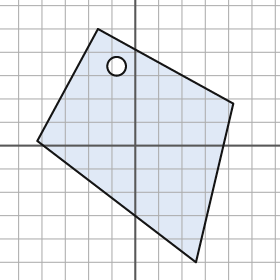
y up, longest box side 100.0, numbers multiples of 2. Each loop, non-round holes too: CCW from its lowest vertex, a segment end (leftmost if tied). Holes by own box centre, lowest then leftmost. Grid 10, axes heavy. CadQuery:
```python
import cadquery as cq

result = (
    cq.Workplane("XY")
    .moveTo(26.0, -50.0)
    .lineTo(42.0, 18.0)
    .lineTo(-16.0, 50.0)
    .lineTo(-42.0, 2.0)
    .close()
    .moveTo(-8.0, 34.0)
    .circle(4.0)
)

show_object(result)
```